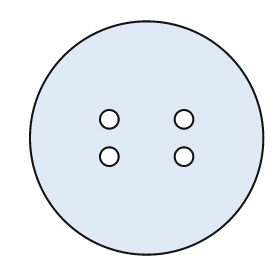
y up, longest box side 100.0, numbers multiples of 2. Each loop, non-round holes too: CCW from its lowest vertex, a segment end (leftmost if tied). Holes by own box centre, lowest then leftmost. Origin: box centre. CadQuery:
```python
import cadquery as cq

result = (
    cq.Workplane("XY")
    .moveTo(0.0, 0.0)
    .circle(50.0)
    .moveTo(-16.0, -8.0)
    .circle(4.0)
    .moveTo(16.0, -8.0)
    .circle(4.0)
    .moveTo(-16.0, 8.0)
    .circle(4.0)
    .moveTo(16.0, 8.0)
    .circle(4.0)
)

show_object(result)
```